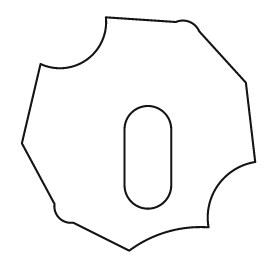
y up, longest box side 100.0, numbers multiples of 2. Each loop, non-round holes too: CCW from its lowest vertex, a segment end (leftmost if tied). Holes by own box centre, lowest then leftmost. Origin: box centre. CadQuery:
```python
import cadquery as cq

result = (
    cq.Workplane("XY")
    .moveTo(-4.0, -50.0)
    .threePointArc((12.0, -42.0), (30.0, -40.0))
    .threePointArc((34.0, -22.0), (50.0, -12.0))
    .lineTo(46.0, 22.0)
    .lineTo(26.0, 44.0)
    .threePointArc((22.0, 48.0), (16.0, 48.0))
    .lineTo(-14.0, 50.0)
    .threePointArc((-22.0, 32.0), (-42.0, 30.0))
    .lineTo(-50.0, -4.0)
    .lineTo(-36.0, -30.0)
    .threePointArc((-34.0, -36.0), (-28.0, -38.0))
    .close()
    .moveTo(-6.0, -22.0)
    .threePointArc((4.0, -32.0), (14.0, -22.0))
    .lineTo(14.0, 2.0)
    .threePointArc((4.0, 12.0), (-6.0, 2.0))
    .close()
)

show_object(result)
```